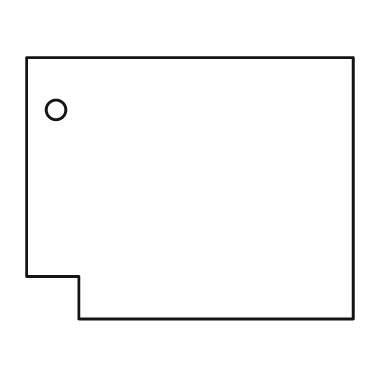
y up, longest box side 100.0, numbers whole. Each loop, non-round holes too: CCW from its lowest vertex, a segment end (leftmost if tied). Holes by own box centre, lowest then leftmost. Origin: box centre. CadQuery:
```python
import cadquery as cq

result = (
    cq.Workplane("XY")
    .moveTo(-34.0, -40.0)
    .lineTo(50.0, -40.0)
    .lineTo(50.0, 40.0)
    .lineTo(-50.0, 40.0)
    .lineTo(-50.0, -27.0)
    .lineTo(-34.0, -27.0)
    .close()
    .moveTo(-41.0, 24.0)
    .circle(3.0)
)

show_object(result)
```